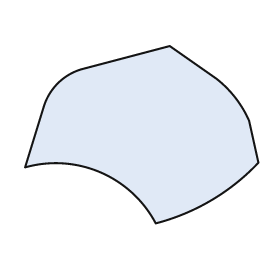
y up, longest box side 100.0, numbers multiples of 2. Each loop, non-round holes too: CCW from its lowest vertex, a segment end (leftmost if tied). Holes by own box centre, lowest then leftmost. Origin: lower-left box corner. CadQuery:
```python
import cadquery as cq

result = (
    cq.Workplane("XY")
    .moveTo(56.0, 0.0)
    .threePointArc((80.0, 10.0), (100.0, 26.0))
    .lineTo(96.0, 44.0)
    .threePointArc((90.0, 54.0), (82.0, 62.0))
    .lineTo(62.0, 76.0)
    .lineTo(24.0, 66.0)
    .threePointArc((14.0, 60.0), (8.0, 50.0))
    .lineTo(0.0, 24.0)
    .threePointArc((32.0, 22.0), (56.0, 0.0))
    .close()
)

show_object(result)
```